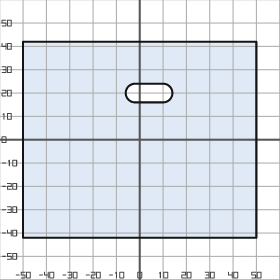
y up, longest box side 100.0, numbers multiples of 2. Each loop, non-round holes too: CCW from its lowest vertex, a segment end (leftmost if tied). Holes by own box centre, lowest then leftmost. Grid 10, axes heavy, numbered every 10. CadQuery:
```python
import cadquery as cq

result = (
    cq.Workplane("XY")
    .moveTo(-50.0, -42.0)
    .lineTo(50.0, -42.0)
    .lineTo(50.0, 42.0)
    .lineTo(-50.0, 42.0)
    .close()
    .moveTo(-2.0, 16.0)
    .lineTo(10.0, 16.0)
    .threePointArc((14.0, 20.0), (10.0, 24.0))
    .lineTo(-2.0, 24.0)
    .threePointArc((-6.0, 20.0), (-2.0, 16.0))
    .close()
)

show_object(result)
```